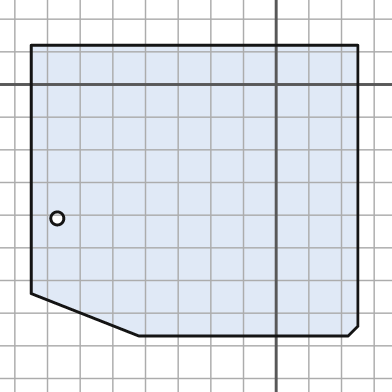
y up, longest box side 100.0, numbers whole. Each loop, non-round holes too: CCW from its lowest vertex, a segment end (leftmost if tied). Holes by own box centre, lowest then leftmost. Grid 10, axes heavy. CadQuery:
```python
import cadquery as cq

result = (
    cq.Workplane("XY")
    .moveTo(-42.0, -77.0)
    .lineTo(22.0, -77.0)
    .lineTo(25.0, -74.0)
    .lineTo(25.0, 12.0)
    .lineTo(-75.0, 12.0)
    .lineTo(-75.0, -64.0)
    .close()
    .moveTo(-67.0, -41.0)
    .circle(2.0)
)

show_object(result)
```